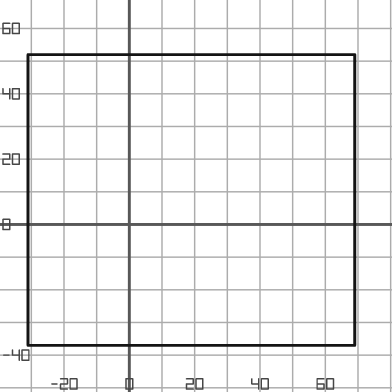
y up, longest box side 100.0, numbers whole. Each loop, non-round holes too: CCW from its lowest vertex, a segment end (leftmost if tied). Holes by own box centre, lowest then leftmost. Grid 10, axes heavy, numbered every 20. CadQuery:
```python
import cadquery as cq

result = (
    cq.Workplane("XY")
    .moveTo(-31.0, -37.0)
    .lineTo(69.0, -37.0)
    .lineTo(69.0, 52.0)
    .lineTo(-31.0, 52.0)
    .close()
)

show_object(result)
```